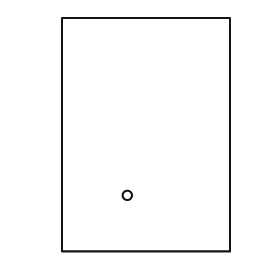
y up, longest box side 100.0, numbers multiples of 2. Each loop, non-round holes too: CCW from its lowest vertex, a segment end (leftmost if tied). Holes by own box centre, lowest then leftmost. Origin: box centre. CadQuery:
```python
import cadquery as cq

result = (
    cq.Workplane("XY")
    .moveTo(-36.0, -50.0)
    .lineTo(36.0, -50.0)
    .lineTo(36.0, 50.0)
    .lineTo(-36.0, 50.0)
    .close()
    .moveTo(-8.0, -26.0)
    .circle(2.0)
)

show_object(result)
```